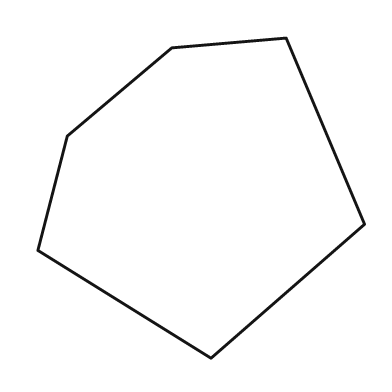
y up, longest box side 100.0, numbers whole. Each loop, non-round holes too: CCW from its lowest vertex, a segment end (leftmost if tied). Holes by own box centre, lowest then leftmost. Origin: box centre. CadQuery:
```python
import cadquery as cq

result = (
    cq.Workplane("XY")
    .moveTo(3.0, -49.0)
    .lineTo(50.0, -8.0)
    .lineTo(26.0, 49.0)
    .lineTo(-9.0, 46.0)
    .lineTo(-41.0, 19.0)
    .lineTo(-50.0, -16.0)
    .close()
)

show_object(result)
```